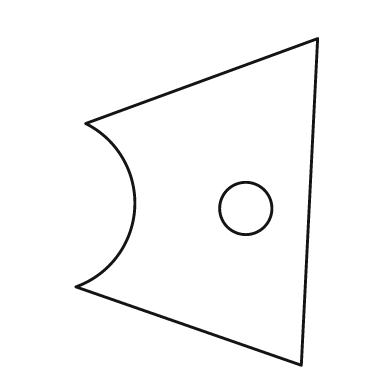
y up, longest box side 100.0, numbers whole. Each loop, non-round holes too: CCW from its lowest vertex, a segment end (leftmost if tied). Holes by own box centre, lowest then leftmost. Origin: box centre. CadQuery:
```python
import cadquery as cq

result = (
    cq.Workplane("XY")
    .moveTo(32.0, -50.0)
    .lineTo(37.0, 50.0)
    .lineTo(-34.0, 24.0)
    .threePointArc((-19.0, -2.0), (-37.0, -26.0))
    .close()
    .moveTo(15.0, -2.0)
    .circle(8.0)
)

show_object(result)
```